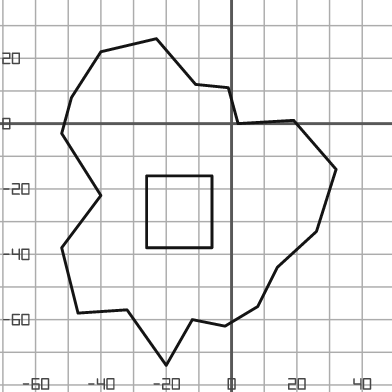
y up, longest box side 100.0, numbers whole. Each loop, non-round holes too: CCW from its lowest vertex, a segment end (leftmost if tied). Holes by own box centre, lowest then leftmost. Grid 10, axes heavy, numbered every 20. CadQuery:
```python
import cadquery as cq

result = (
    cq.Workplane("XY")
    .moveTo(-20.0, -74.0)
    .lineTo(-12.0, -60.0)
    .lineTo(-2.0, -62.0)
    .lineTo(8.0, -56.0)
    .lineTo(14.0, -44.0)
    .lineTo(26.0, -33.0)
    .lineTo(32.0, -14.0)
    .lineTo(19.0, 1.0)
    .lineTo(2.0, 0.0)
    .lineTo(-1.0, 11.0)
    .lineTo(-11.0, 12.0)
    .lineTo(-23.0, 26.0)
    .lineTo(-40.0, 22.0)
    .lineTo(-49.0, 8.0)
    .lineTo(-52.0, -3.0)
    .lineTo(-40.0, -22.0)
    .lineTo(-52.0, -38.0)
    .lineTo(-47.0, -58.0)
    .lineTo(-32.0, -57.0)
    .close()
    .moveTo(-26.0, -38.0)
    .lineTo(-6.0, -38.0)
    .lineTo(-6.0, -16.0)
    .lineTo(-26.0, -16.0)
    .close()
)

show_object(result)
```